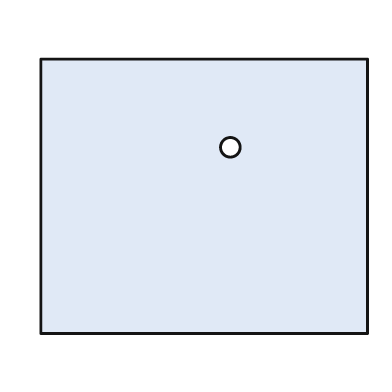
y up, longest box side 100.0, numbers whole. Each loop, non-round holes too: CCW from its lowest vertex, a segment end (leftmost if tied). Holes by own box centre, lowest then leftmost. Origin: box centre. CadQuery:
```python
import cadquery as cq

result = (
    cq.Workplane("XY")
    .moveTo(-50.0, -42.0)
    .lineTo(50.0, -42.0)
    .lineTo(50.0, 42.0)
    .lineTo(-50.0, 42.0)
    .close()
    .moveTo(8.0, 15.0)
    .circle(3.0)
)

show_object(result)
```